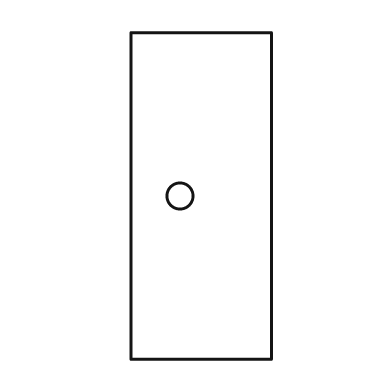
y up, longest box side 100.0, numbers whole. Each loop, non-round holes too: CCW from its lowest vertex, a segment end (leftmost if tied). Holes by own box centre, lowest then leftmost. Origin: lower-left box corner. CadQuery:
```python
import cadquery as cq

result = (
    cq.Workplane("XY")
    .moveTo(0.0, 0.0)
    .lineTo(43.0, 0.0)
    .lineTo(43.0, 100.0)
    .lineTo(0.0, 100.0)
    .close()
    .moveTo(15.0, 50.0)
    .circle(4.0)
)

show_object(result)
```